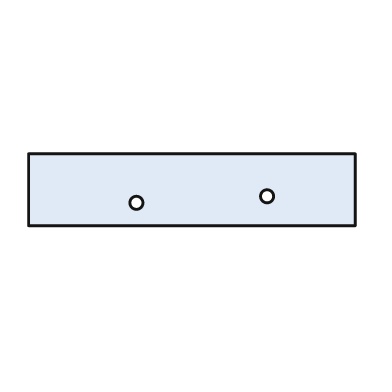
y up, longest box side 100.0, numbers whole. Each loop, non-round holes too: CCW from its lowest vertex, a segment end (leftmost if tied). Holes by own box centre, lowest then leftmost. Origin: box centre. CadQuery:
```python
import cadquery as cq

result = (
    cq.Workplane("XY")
    .moveTo(-50.0, -11.0)
    .lineTo(50.0, -11.0)
    .lineTo(50.0, 11.0)
    .lineTo(-50.0, 11.0)
    .close()
    .moveTo(-17.0, -4.0)
    .circle(2.0)
    .moveTo(23.0, -2.0)
    .circle(2.0)
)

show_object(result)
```